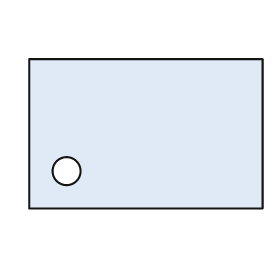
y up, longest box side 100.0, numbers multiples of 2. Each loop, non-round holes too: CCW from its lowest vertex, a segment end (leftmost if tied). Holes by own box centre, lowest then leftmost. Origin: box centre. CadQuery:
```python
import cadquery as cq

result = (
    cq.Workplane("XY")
    .moveTo(-50.0, -32.0)
    .lineTo(50.0, -32.0)
    .lineTo(50.0, 32.0)
    .lineTo(-50.0, 32.0)
    .close()
    .moveTo(-34.0, -16.0)
    .circle(6.0)
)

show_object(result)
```